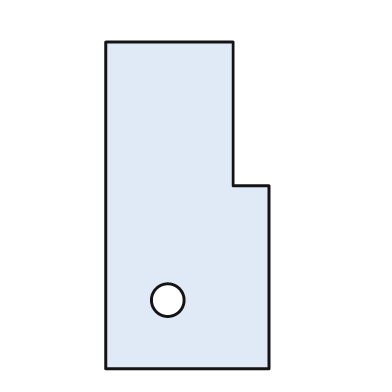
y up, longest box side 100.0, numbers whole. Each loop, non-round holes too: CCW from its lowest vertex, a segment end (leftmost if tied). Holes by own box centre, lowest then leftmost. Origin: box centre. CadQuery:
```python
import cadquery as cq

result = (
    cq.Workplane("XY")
    .moveTo(-25.0, -50.0)
    .lineTo(25.0, -50.0)
    .lineTo(25.0, 6.0)
    .lineTo(14.0, 6.0)
    .lineTo(14.0, 50.0)
    .lineTo(-25.0, 50.0)
    .close()
    .moveTo(-6.0, -29.0)
    .circle(5.0)
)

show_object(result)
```